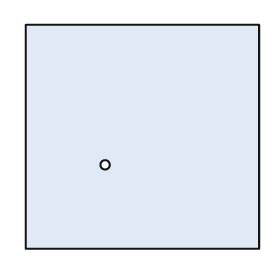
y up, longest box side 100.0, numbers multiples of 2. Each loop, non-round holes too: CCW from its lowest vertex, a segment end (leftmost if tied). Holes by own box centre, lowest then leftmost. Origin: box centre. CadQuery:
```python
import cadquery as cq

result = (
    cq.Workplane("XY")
    .moveTo(-50.0, -48.0)
    .lineTo(50.0, -48.0)
    .lineTo(50.0, 48.0)
    .lineTo(-50.0, 48.0)
    .close()
    .moveTo(-16.0, -12.0)
    .circle(2.0)
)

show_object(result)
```